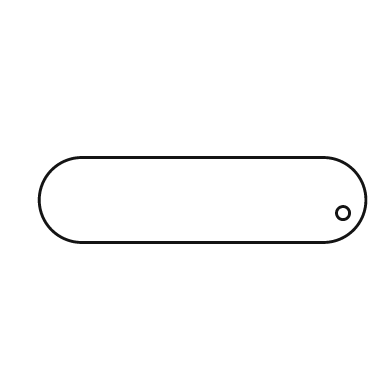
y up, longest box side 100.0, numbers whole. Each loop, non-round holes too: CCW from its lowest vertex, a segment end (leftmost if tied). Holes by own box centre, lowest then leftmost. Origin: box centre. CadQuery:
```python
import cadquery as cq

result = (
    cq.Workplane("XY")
    .moveTo(-37.0, -13.0)
    .lineTo(37.0, -13.0)
    .threePointArc((50.0, 0.0), (37.0, 13.0))
    .lineTo(-37.0, 13.0)
    .threePointArc((-50.0, 0.0), (-37.0, -13.0))
    .close()
    .moveTo(43.0, -4.0)
    .circle(2.0)
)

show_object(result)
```